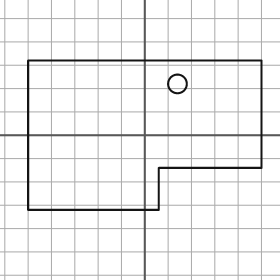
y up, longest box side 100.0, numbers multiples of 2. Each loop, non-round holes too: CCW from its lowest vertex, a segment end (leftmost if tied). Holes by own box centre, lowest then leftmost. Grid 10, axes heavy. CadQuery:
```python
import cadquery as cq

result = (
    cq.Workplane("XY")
    .moveTo(-50.0, -32.0)
    .lineTo(6.0, -32.0)
    .lineTo(6.0, -14.0)
    .lineTo(50.0, -14.0)
    .lineTo(50.0, 32.0)
    .lineTo(-50.0, 32.0)
    .close()
    .moveTo(14.0, 22.0)
    .circle(4.0)
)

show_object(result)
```